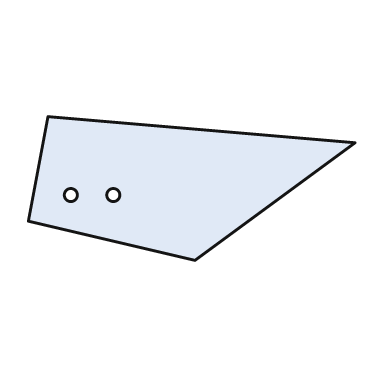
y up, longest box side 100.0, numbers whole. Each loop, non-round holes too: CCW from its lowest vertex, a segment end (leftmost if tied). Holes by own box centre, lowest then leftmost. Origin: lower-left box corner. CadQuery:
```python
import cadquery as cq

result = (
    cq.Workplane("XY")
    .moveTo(51.0, 0.0)
    .lineTo(100.0, 36.0)
    .lineTo(6.0, 44.0)
    .lineTo(0.0, 12.0)
    .close()
    .moveTo(13.0, 20.0)
    .circle(2.0)
    .moveTo(26.0, 20.0)
    .circle(2.0)
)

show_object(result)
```